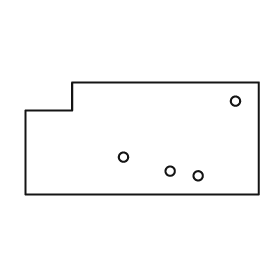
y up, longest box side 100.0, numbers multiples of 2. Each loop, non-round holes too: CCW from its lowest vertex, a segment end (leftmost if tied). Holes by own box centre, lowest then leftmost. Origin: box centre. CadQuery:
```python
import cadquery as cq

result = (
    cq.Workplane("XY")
    .moveTo(-50.0, -24.0)
    .lineTo(50.0, -24.0)
    .lineTo(50.0, 24.0)
    .lineTo(-30.0, 24.0)
    .lineTo(-30.0, 12.0)
    .lineTo(-50.0, 12.0)
    .close()
    .moveTo(24.0, -16.0)
    .circle(2.0)
    .moveTo(12.0, -14.0)
    .circle(2.0)
    .moveTo(-8.0, -8.0)
    .circle(2.0)
    .moveTo(40.0, 16.0)
    .circle(2.0)
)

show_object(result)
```